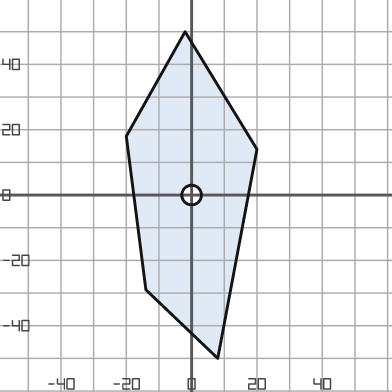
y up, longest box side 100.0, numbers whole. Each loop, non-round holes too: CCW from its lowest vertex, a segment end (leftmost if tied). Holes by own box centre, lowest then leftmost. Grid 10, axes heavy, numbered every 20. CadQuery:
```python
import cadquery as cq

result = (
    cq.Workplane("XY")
    .moveTo(8.0, -50.0)
    .lineTo(20.0, 14.0)
    .lineTo(-2.0, 50.0)
    .lineTo(-20.0, 18.0)
    .lineTo(-14.0, -29.0)
    .close()
    .moveTo(0.0, 0.0)
    .circle(3.0)
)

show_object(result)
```